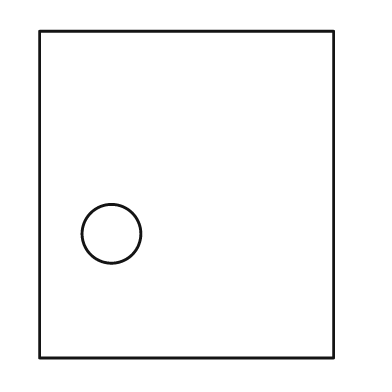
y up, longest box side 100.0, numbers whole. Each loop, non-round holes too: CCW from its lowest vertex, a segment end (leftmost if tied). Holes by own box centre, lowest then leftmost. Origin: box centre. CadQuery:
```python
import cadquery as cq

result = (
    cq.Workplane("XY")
    .moveTo(-45.0, -50.0)
    .lineTo(45.0, -50.0)
    .lineTo(45.0, 50.0)
    .lineTo(-45.0, 50.0)
    .close()
    .moveTo(-23.0, -12.0)
    .circle(9.0)
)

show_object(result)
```